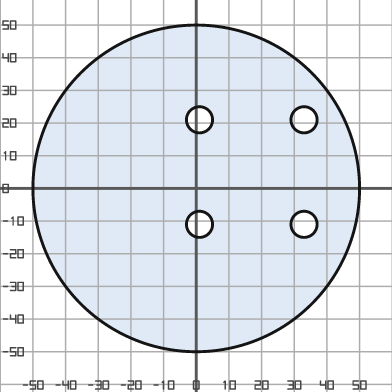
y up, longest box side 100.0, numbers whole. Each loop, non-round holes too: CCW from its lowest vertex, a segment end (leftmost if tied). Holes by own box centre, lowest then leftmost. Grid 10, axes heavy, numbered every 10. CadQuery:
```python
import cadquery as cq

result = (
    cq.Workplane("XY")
    .moveTo(0.0, 0.0)
    .circle(50.0)
    .moveTo(1.0, -11.0)
    .circle(4.0)
    .moveTo(33.0, -11.0)
    .circle(4.0)
    .moveTo(1.0, 21.0)
    .circle(4.0)
    .moveTo(33.0, 21.0)
    .circle(4.0)
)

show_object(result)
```